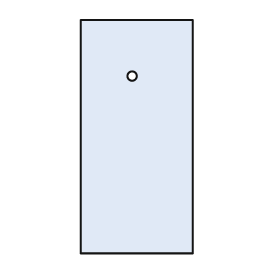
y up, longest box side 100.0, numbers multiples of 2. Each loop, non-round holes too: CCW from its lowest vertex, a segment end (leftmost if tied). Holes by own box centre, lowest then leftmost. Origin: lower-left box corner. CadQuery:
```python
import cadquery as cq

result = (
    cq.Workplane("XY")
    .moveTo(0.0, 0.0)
    .lineTo(48.0, 0.0)
    .lineTo(48.0, 100.0)
    .lineTo(0.0, 100.0)
    .close()
    .moveTo(22.0, 76.0)
    .circle(2.0)
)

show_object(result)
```